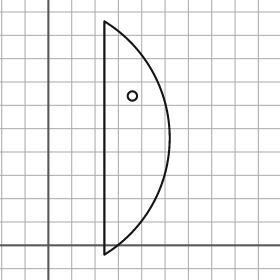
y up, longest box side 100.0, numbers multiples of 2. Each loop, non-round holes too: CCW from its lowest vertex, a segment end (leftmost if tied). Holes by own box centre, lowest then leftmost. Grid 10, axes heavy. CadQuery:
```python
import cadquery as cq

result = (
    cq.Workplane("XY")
    .moveTo(24.0, -4.0)
    .threePointArc((52.0, 46.0), (24.0, 96.0))
    .close()
    .moveTo(36.0, 64.0)
    .circle(2.0)
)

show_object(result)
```